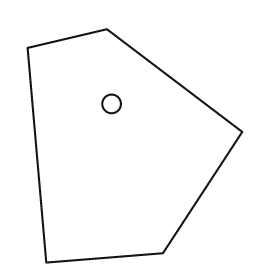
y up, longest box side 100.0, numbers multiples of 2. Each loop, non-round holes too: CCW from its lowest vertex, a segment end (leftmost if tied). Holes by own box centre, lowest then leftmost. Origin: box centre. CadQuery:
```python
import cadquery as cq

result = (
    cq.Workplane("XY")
    .moveTo(-38.0, -50.0)
    .lineTo(12.0, -46.0)
    .lineTo(46.0, 6.0)
    .lineTo(-12.0, 50.0)
    .lineTo(-46.0, 42.0)
    .close()
    .moveTo(-10.0, 18.0)
    .circle(4.0)
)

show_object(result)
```